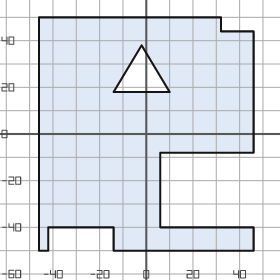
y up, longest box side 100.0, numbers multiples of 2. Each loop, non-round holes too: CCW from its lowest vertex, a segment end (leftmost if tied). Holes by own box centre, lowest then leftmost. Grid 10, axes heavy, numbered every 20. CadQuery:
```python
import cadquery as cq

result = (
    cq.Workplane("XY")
    .moveTo(-46.0, -50.0)
    .lineTo(-42.0, -50.0)
    .lineTo(-42.0, -40.0)
    .lineTo(-14.0, -40.0)
    .lineTo(-14.0, -50.0)
    .lineTo(46.0, -50.0)
    .lineTo(46.0, -40.0)
    .lineTo(6.0, -40.0)
    .lineTo(6.0, -8.0)
    .lineTo(46.0, -8.0)
    .lineTo(46.0, 44.0)
    .lineTo(32.0, 44.0)
    .lineTo(32.0, 50.0)
    .lineTo(-46.0, 50.0)
    .close()
    .moveTo(-14.0, 18.0)
    .lineTo(10.0, 18.0)
    .lineTo(-2.0, 38.0)
    .close()
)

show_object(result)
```